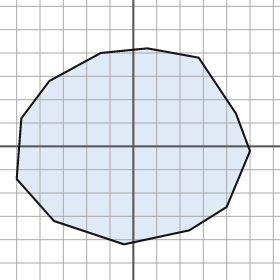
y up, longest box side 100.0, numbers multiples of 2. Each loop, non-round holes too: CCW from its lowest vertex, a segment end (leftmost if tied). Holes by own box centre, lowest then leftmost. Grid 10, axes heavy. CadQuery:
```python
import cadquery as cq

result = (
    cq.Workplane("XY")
    .moveTo(-4.0, -42.0)
    .lineTo(24.0, -36.0)
    .lineTo(40.0, -26.0)
    .lineTo(50.0, -2.0)
    .lineTo(44.0, 14.0)
    .lineTo(28.0, 38.0)
    .lineTo(6.0, 42.0)
    .lineTo(-14.0, 40.0)
    .lineTo(-36.0, 28.0)
    .lineTo(-48.0, 12.0)
    .lineTo(-50.0, -14.0)
    .lineTo(-34.0, -32.0)
    .close()
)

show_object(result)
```